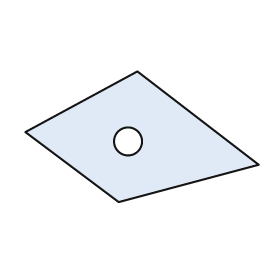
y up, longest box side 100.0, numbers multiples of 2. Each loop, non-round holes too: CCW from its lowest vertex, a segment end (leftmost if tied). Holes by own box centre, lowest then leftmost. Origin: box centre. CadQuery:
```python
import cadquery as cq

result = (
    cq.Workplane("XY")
    .moveTo(-10.0, -28.0)
    .lineTo(50.0, -12.0)
    .lineTo(-2.0, 28.0)
    .lineTo(-50.0, 2.0)
    .close()
    .moveTo(-6.0, -2.0)
    .circle(6.0)
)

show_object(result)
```